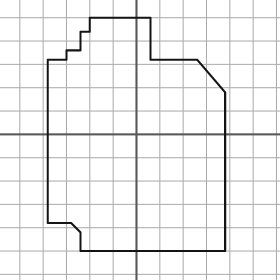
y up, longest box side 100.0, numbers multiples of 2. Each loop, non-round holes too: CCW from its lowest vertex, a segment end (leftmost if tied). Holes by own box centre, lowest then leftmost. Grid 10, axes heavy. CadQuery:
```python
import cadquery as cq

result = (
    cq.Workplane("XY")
    .moveTo(-24.0, -50.0)
    .lineTo(38.0, -50.0)
    .lineTo(38.0, 18.0)
    .lineTo(26.0, 32.0)
    .lineTo(6.0, 32.0)
    .lineTo(6.0, 50.0)
    .lineTo(-20.0, 50.0)
    .lineTo(-20.0, 44.0)
    .lineTo(-24.0, 44.0)
    .lineTo(-24.0, 36.0)
    .lineTo(-30.0, 36.0)
    .lineTo(-30.0, 32.0)
    .lineTo(-38.0, 32.0)
    .lineTo(-38.0, -38.0)
    .lineTo(-28.0, -38.0)
    .lineTo(-24.0, -42.0)
    .close()
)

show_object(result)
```